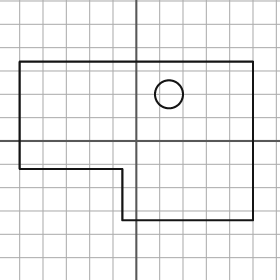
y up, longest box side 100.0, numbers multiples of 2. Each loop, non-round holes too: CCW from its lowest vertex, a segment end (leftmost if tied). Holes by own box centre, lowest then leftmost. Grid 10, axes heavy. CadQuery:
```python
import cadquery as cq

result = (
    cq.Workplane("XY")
    .moveTo(-6.0, -34.0)
    .lineTo(50.0, -34.0)
    .lineTo(50.0, 34.0)
    .lineTo(-50.0, 34.0)
    .lineTo(-50.0, -12.0)
    .lineTo(-6.0, -12.0)
    .close()
    .moveTo(14.0, 20.0)
    .circle(6.0)
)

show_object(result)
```